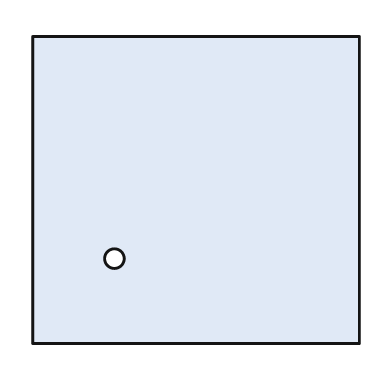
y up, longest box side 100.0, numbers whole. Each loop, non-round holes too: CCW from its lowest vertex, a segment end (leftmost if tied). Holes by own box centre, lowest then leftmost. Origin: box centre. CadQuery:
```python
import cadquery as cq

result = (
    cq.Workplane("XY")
    .moveTo(-50.0, -47.0)
    .lineTo(50.0, -47.0)
    .lineTo(50.0, 47.0)
    .lineTo(-50.0, 47.0)
    .close()
    .moveTo(-25.0, -21.0)
    .circle(3.0)
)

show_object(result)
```